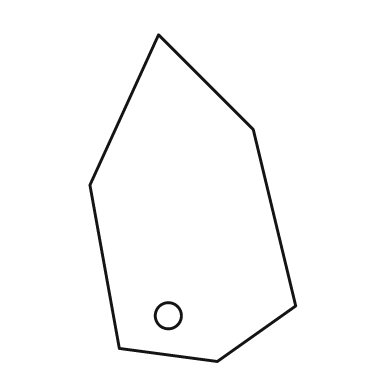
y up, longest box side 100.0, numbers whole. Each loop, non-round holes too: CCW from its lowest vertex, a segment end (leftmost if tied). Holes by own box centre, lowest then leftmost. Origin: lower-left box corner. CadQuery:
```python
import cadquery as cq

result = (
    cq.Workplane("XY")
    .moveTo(39.0, 0.0)
    .lineTo(63.0, 17.0)
    .lineTo(50.0, 71.0)
    .lineTo(21.0, 100.0)
    .lineTo(0.0, 54.0)
    .lineTo(9.0, 4.0)
    .close()
    .moveTo(24.0, 14.0)
    .circle(4.0)
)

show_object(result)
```